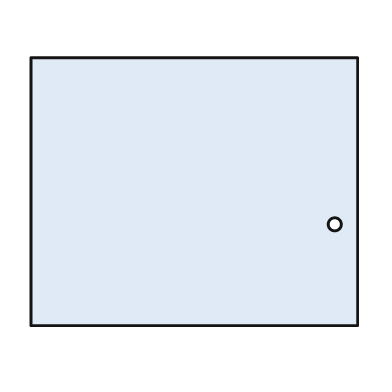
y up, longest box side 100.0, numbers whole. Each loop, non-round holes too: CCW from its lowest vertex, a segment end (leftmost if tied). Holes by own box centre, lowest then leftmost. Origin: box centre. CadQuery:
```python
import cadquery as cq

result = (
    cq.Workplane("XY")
    .moveTo(-50.0, -41.0)
    .lineTo(50.0, -41.0)
    .lineTo(50.0, 41.0)
    .lineTo(-50.0, 41.0)
    .close()
    .moveTo(43.0, -10.0)
    .circle(2.0)
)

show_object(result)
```